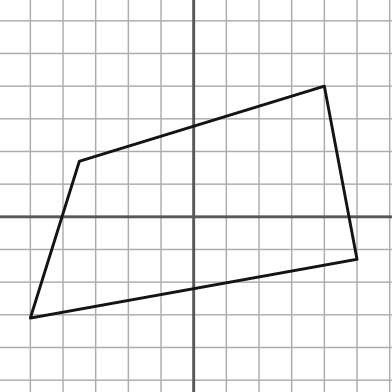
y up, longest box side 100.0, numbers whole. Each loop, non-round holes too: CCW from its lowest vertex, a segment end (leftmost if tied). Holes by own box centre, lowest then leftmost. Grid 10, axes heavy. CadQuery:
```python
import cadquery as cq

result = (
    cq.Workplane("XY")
    .moveTo(-50.0, -31.0)
    .lineTo(50.0, -13.0)
    .lineTo(40.0, 40.0)
    .lineTo(-35.0, 17.0)
    .close()
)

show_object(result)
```